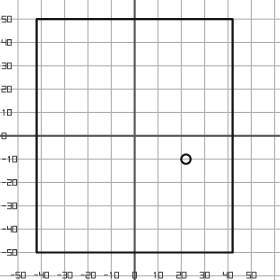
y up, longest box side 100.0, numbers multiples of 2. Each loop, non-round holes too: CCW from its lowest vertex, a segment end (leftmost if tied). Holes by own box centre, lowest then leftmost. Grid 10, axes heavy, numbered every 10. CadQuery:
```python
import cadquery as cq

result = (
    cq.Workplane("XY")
    .moveTo(-42.0, -50.0)
    .lineTo(42.0, -50.0)
    .lineTo(42.0, 50.0)
    .lineTo(-42.0, 50.0)
    .close()
    .moveTo(22.0, -10.0)
    .circle(2.0)
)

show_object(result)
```